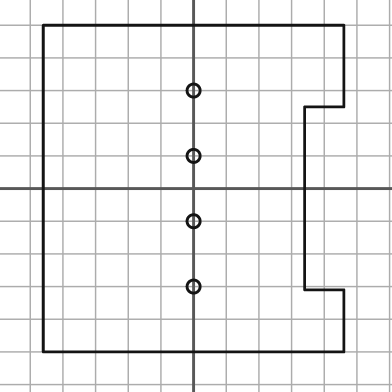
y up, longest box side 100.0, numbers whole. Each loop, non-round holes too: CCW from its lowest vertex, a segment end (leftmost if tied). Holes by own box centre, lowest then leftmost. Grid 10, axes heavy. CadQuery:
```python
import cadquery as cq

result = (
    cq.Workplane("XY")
    .moveTo(-46.0, -50.0)
    .lineTo(46.0, -50.0)
    .lineTo(46.0, -31.0)
    .lineTo(34.0, -31.0)
    .lineTo(34.0, 25.0)
    .lineTo(46.0, 25.0)
    .lineTo(46.0, 50.0)
    .lineTo(-46.0, 50.0)
    .close()
    .moveTo(0.0, -30.0)
    .circle(2.0)
    .moveTo(0.0, -10.0)
    .circle(2.0)
    .moveTo(0.0, 10.0)
    .circle(2.0)
    .moveTo(0.0, 30.0)
    .circle(2.0)
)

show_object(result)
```